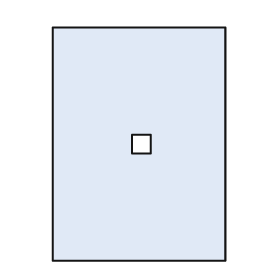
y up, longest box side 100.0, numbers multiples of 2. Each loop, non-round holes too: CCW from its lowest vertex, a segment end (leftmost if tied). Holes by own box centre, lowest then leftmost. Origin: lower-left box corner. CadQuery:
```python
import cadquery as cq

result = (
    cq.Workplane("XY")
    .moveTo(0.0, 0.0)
    .lineTo(74.0, 0.0)
    .lineTo(74.0, 100.0)
    .lineTo(0.0, 100.0)
    .close()
    .moveTo(34.0, 46.0)
    .lineTo(42.0, 46.0)
    .lineTo(42.0, 54.0)
    .lineTo(34.0, 54.0)
    .close()
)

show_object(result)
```